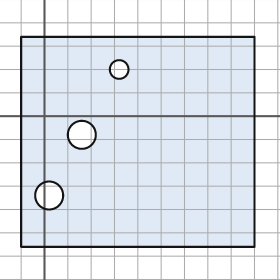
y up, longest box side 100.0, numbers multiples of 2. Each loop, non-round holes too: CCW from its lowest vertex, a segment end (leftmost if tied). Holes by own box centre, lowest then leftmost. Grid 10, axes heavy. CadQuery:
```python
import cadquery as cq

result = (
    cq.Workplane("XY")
    .moveTo(-10.0, -56.0)
    .lineTo(90.0, -56.0)
    .lineTo(90.0, 34.0)
    .lineTo(-10.0, 34.0)
    .close()
    .moveTo(2.0, -34.0)
    .circle(6.0)
    .moveTo(16.0, -8.0)
    .circle(6.0)
    .moveTo(32.0, 20.0)
    .circle(4.0)
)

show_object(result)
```